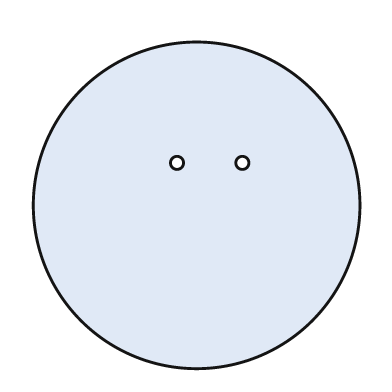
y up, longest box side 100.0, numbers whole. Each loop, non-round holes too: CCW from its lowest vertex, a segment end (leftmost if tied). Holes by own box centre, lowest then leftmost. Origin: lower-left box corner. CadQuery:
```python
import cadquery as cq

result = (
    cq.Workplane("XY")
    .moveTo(50.0, 50.0)
    .circle(50.0)
    .moveTo(44.0, 63.0)
    .circle(2.0)
    .moveTo(64.0, 63.0)
    .circle(2.0)
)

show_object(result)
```